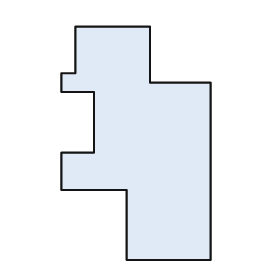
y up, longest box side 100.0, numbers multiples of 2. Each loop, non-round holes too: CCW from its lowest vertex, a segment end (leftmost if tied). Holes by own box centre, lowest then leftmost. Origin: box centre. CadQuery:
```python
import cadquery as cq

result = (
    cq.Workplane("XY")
    .moveTo(-4.0, -50.0)
    .lineTo(32.0, -50.0)
    .lineTo(32.0, 26.0)
    .lineTo(6.0, 26.0)
    .lineTo(6.0, 50.0)
    .lineTo(-26.0, 50.0)
    .lineTo(-26.0, 30.0)
    .lineTo(-32.0, 30.0)
    .lineTo(-32.0, 22.0)
    .lineTo(-18.0, 22.0)
    .lineTo(-18.0, -4.0)
    .lineTo(-32.0, -4.0)
    .lineTo(-32.0, -20.0)
    .lineTo(-4.0, -20.0)
    .close()
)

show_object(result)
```